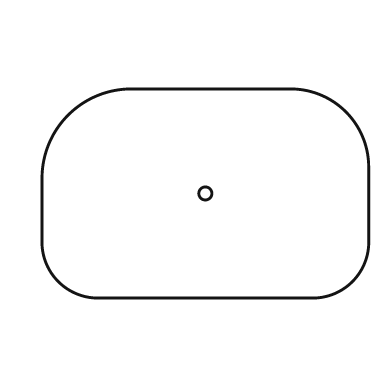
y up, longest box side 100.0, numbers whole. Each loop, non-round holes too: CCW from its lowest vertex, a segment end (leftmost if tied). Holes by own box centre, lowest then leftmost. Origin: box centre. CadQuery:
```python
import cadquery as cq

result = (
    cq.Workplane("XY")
    .moveTo(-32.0, -32.0)
    .lineTo(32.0, -32.0)
    .threePointArc((45.0, -27.0), (50.0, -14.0))
    .lineTo(50.0, 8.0)
    .threePointArc((43.0, 25.0), (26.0, 32.0))
    .lineTo(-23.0, 32.0)
    .threePointArc((-42.0, 24.0), (-50.0, 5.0))
    .lineTo(-50.0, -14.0)
    .threePointArc((-45.0, -27.0), (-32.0, -32.0))
    .close()
    .moveTo(0.0, 0.0)
    .circle(2.0)
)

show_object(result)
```